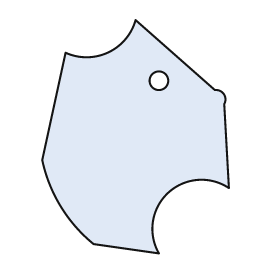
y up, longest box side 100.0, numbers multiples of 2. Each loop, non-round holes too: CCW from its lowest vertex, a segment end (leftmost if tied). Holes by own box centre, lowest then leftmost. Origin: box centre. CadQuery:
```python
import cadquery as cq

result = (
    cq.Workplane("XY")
    .moveTo(10.0, -50.0)
    .threePointArc((14.0, -24.0), (40.0, -22.0))
    .lineTo(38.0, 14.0)
    .threePointArc((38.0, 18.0), (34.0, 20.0))
    .lineTo(0.0, 50.0)
    .threePointArc((-12.0, 36.0), (-30.0, 36.0))
    .lineTo(-40.0, -10.0)
    .threePointArc((-32.0, -30.0), (-18.0, -46.0))
    .close()
    .moveTo(10.0, 24.0)
    .circle(4.0)
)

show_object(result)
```